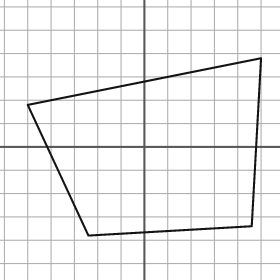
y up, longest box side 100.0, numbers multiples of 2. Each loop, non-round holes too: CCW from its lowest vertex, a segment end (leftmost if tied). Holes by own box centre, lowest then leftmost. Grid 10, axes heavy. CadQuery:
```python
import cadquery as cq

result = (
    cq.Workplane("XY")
    .moveTo(-24.0, -38.0)
    .lineTo(46.0, -34.0)
    .lineTo(50.0, 38.0)
    .lineTo(-50.0, 18.0)
    .close()
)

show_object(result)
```